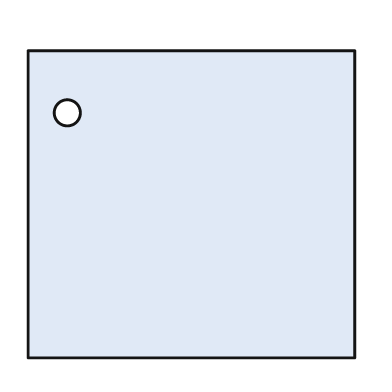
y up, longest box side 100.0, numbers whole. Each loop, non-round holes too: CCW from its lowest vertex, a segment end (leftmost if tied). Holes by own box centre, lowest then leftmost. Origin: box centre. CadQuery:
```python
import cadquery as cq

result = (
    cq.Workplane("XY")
    .moveTo(-50.0, -47.0)
    .lineTo(50.0, -47.0)
    .lineTo(50.0, 47.0)
    .lineTo(-50.0, 47.0)
    .close()
    .moveTo(-38.0, 28.0)
    .circle(4.0)
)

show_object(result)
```